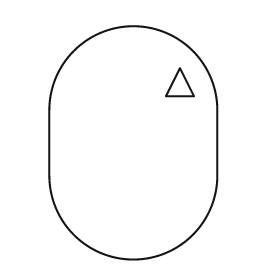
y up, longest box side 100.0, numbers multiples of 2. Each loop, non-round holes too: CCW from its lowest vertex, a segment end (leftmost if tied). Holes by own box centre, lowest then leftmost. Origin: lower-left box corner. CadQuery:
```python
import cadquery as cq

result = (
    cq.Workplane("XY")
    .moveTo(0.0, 36.0)
    .threePointArc((36.0, 0.0), (72.0, 36.0))
    .lineTo(72.0, 64.0)
    .threePointArc((36.0, 100.0), (0.0, 64.0))
    .close()
    .moveTo(50.0, 70.0)
    .lineTo(62.0, 70.0)
    .lineTo(56.0, 82.0)
    .close()
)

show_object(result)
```